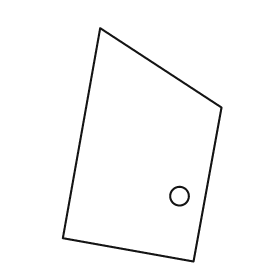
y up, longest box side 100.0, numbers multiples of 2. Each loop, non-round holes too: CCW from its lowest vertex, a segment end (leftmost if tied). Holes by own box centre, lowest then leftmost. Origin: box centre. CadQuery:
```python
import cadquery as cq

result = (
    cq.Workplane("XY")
    .moveTo(22.0, -50.0)
    .lineTo(34.0, 16.0)
    .lineTo(-18.0, 50.0)
    .lineTo(-34.0, -40.0)
    .close()
    .moveTo(16.0, -22.0)
    .circle(4.0)
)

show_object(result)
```